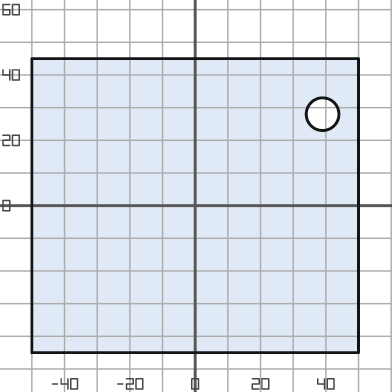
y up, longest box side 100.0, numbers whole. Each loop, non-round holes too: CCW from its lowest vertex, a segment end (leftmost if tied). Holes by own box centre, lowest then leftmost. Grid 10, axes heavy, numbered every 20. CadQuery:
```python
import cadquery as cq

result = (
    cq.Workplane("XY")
    .moveTo(-50.0, -45.0)
    .lineTo(50.0, -45.0)
    .lineTo(50.0, 45.0)
    .lineTo(-50.0, 45.0)
    .close()
    .moveTo(39.0, 28.0)
    .circle(5.0)
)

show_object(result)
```